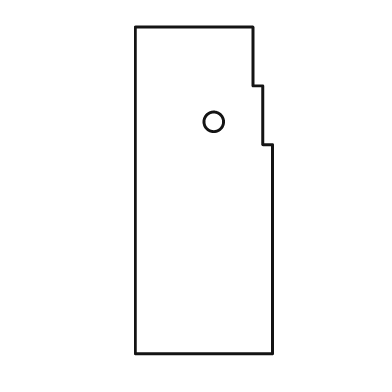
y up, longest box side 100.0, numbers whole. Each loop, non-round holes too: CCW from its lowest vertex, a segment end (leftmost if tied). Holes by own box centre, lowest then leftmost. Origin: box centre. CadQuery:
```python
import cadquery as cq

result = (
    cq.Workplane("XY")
    .moveTo(-21.0, -50.0)
    .lineTo(21.0, -50.0)
    .lineTo(21.0, 14.0)
    .lineTo(18.0, 14.0)
    .lineTo(18.0, 32.0)
    .lineTo(15.0, 32.0)
    .lineTo(15.0, 50.0)
    .lineTo(-21.0, 50.0)
    .close()
    .moveTo(3.0, 21.0)
    .circle(3.0)
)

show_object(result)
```